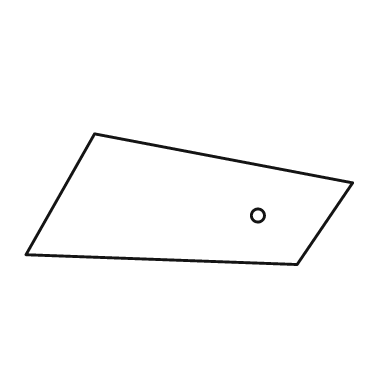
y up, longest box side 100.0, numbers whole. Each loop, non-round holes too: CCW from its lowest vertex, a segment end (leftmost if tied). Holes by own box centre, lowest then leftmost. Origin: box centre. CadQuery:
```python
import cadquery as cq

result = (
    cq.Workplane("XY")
    .moveTo(33.0, -20.0)
    .lineTo(50.0, 5.0)
    .lineTo(-29.0, 20.0)
    .lineTo(-50.0, -17.0)
    .close()
    .moveTo(21.0, -5.0)
    .circle(2.0)
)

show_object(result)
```